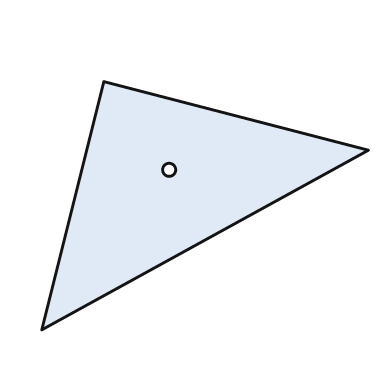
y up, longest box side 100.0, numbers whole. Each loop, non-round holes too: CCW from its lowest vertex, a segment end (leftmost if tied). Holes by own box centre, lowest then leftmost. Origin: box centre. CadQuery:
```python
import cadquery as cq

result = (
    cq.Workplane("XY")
    .moveTo(-50.0, -38.0)
    .lineTo(50.0, 17.0)
    .lineTo(-31.0, 38.0)
    .close()
    .moveTo(-11.0, 11.0)
    .circle(2.0)
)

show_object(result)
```